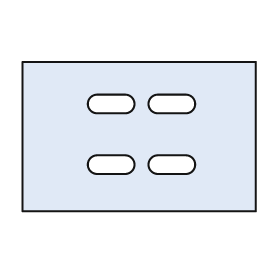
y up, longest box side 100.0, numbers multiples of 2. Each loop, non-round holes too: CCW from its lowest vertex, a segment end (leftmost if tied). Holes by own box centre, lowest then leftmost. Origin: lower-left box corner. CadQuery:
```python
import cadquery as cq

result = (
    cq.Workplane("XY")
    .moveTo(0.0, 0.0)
    .lineTo(100.0, 0.0)
    .lineTo(100.0, 64.0)
    .lineTo(0.0, 64.0)
    .close()
    .moveTo(32.0, 16.0)
    .lineTo(44.0, 16.0)
    .threePointArc((48.0, 20.0), (44.0, 24.0))
    .lineTo(32.0, 24.0)
    .threePointArc((28.0, 20.0), (32.0, 16.0))
    .close()
    .moveTo(58.0, 16.0)
    .lineTo(70.0, 16.0)
    .threePointArc((74.0, 20.0), (70.0, 24.0))
    .lineTo(58.0, 24.0)
    .threePointArc((54.0, 20.0), (58.0, 16.0))
    .close()
    .moveTo(32.0, 42.0)
    .lineTo(44.0, 42.0)
    .threePointArc((48.0, 46.0), (44.0, 50.0))
    .lineTo(32.0, 50.0)
    .threePointArc((28.0, 46.0), (32.0, 42.0))
    .close()
    .moveTo(58.0, 42.0)
    .lineTo(70.0, 42.0)
    .threePointArc((74.0, 46.0), (70.0, 50.0))
    .lineTo(58.0, 50.0)
    .threePointArc((54.0, 46.0), (58.0, 42.0))
    .close()
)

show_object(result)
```